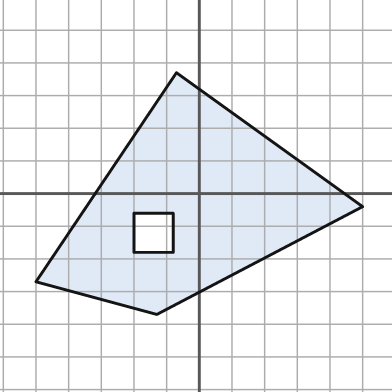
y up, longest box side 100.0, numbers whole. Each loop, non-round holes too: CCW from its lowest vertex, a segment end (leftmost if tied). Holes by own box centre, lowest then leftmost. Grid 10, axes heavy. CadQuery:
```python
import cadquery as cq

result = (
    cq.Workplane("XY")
    .moveTo(-13.0, -37.0)
    .lineTo(50.0, -4.0)
    .lineTo(-7.0, 37.0)
    .lineTo(-50.0, -27.0)
    .close()
    .moveTo(-20.0, -18.0)
    .lineTo(-8.0, -18.0)
    .lineTo(-8.0, -6.0)
    .lineTo(-20.0, -6.0)
    .close()
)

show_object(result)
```